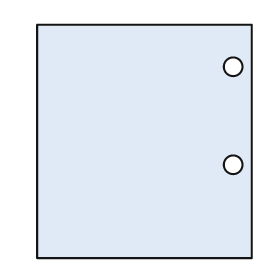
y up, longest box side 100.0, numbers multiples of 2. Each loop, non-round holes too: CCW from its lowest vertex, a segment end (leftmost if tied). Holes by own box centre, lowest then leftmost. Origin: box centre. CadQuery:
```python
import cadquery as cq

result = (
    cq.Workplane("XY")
    .moveTo(-46.0, -50.0)
    .lineTo(46.0, -50.0)
    .lineTo(46.0, 50.0)
    .lineTo(-46.0, 50.0)
    .close()
    .moveTo(38.0, -10.0)
    .circle(4.0)
    .moveTo(38.0, 32.0)
    .circle(4.0)
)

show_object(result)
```